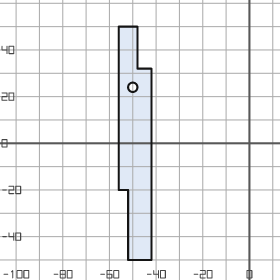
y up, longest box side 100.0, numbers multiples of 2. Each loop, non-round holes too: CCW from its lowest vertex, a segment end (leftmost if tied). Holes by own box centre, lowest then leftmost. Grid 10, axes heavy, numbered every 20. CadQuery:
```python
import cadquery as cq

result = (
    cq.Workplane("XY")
    .moveTo(-52.0, -50.0)
    .lineTo(-42.0, -50.0)
    .lineTo(-42.0, 32.0)
    .lineTo(-48.0, 32.0)
    .lineTo(-48.0, 50.0)
    .lineTo(-56.0, 50.0)
    .lineTo(-56.0, -20.0)
    .lineTo(-52.0, -20.0)
    .close()
    .moveTo(-50.0, 24.0)
    .circle(2.0)
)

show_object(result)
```